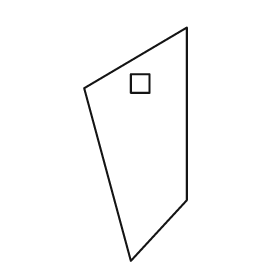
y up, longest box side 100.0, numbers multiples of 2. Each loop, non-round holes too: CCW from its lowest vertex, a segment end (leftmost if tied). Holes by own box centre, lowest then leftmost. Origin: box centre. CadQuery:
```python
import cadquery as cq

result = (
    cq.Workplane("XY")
    .moveTo(-2.0, -50.0)
    .lineTo(22.0, -24.0)
    .lineTo(22.0, 50.0)
    .lineTo(-22.0, 24.0)
    .close()
    .moveTo(-2.0, 22.0)
    .lineTo(6.0, 22.0)
    .lineTo(6.0, 30.0)
    .lineTo(-2.0, 30.0)
    .close()
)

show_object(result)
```